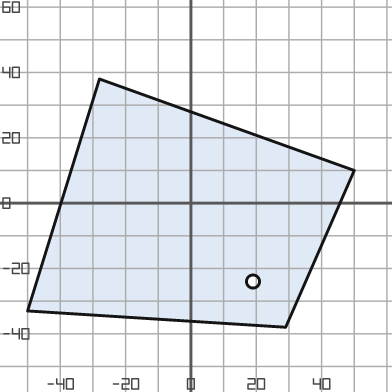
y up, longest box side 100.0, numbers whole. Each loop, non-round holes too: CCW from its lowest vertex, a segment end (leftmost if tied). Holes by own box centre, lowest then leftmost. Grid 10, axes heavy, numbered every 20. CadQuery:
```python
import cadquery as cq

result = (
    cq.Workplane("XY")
    .moveTo(29.0, -38.0)
    .lineTo(50.0, 10.0)
    .lineTo(-28.0, 38.0)
    .lineTo(-50.0, -33.0)
    .close()
    .moveTo(19.0, -24.0)
    .circle(2.0)
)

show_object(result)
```